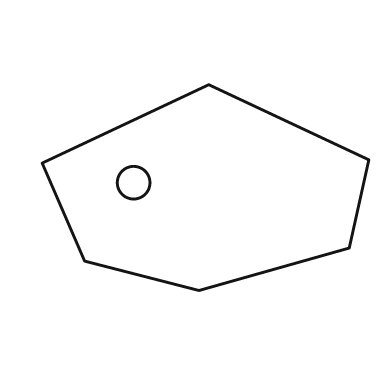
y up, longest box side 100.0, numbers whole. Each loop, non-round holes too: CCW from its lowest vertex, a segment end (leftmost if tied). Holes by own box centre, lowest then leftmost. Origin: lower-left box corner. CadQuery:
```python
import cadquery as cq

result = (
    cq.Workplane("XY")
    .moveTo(48.0, 0.0)
    .lineTo(94.0, 13.0)
    .lineTo(100.0, 40.0)
    .lineTo(51.0, 63.0)
    .lineTo(0.0, 39.0)
    .lineTo(13.0, 9.0)
    .close()
    .moveTo(28.0, 33.0)
    .circle(5.0)
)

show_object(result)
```